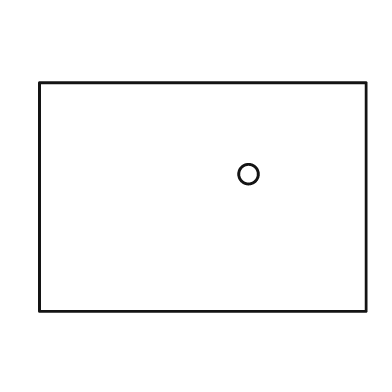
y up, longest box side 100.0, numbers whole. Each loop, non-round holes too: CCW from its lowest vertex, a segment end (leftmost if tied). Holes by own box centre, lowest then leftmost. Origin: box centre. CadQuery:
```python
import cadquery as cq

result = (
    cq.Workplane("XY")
    .moveTo(-50.0, -35.0)
    .lineTo(50.0, -35.0)
    .lineTo(50.0, 35.0)
    .lineTo(-50.0, 35.0)
    .close()
    .moveTo(14.0, 7.0)
    .circle(3.0)
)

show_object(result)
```